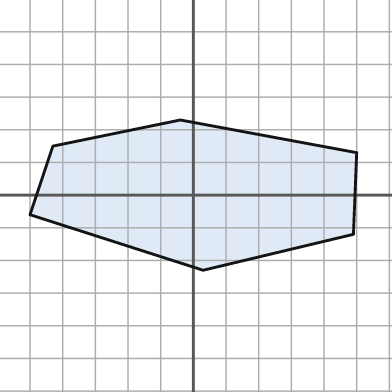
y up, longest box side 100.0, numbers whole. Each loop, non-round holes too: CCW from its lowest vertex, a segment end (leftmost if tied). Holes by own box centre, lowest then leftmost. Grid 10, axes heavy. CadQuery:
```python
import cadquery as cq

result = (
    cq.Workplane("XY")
    .moveTo(3.0, -23.0)
    .lineTo(49.0, -12.0)
    .lineTo(50.0, 13.0)
    .lineTo(-4.0, 23.0)
    .lineTo(-43.0, 15.0)
    .lineTo(-50.0, -6.0)
    .close()
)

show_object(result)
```